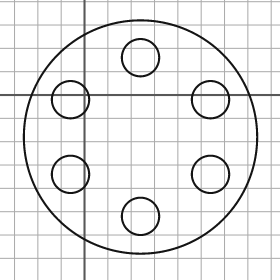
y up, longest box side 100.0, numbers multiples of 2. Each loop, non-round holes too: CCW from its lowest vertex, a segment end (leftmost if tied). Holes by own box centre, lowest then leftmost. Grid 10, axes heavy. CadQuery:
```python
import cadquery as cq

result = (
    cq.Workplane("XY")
    .moveTo(24.0, -18.0)
    .circle(50.0)
    .moveTo(24.0, -52.0)
    .circle(8.0)
    .moveTo(-6.0, -34.0)
    .circle(8.0)
    .moveTo(54.0, -34.0)
    .circle(8.0)
    .moveTo(-6.0, -2.0)
    .circle(8.0)
    .moveTo(54.0, -2.0)
    .circle(8.0)
    .moveTo(24.0, 16.0)
    .circle(8.0)
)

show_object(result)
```